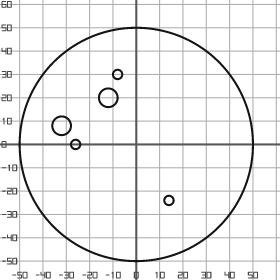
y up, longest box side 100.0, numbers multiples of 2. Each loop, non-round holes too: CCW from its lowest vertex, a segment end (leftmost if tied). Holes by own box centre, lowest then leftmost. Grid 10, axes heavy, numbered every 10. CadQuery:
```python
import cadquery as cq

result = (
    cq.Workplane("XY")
    .moveTo(0.0, 0.0)
    .circle(50.0)
    .moveTo(14.0, -24.0)
    .circle(2.0)
    .moveTo(-26.0, 0.0)
    .circle(2.0)
    .moveTo(-32.0, 8.0)
    .circle(4.0)
    .moveTo(-12.0, 20.0)
    .circle(4.0)
    .moveTo(-8.0, 30.0)
    .circle(2.0)
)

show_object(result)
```